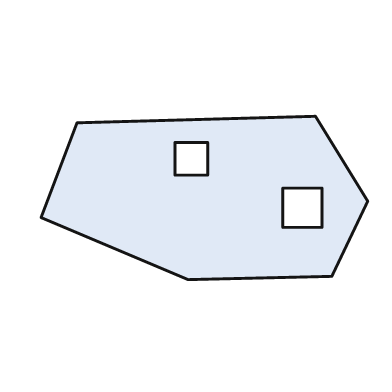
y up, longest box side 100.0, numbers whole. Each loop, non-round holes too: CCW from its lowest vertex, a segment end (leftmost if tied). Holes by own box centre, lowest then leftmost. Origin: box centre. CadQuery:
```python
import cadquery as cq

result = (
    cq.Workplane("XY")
    .moveTo(-5.0, -25.0)
    .lineTo(39.0, -24.0)
    .lineTo(50.0, -1.0)
    .lineTo(34.0, 25.0)
    .lineTo(-39.0, 23.0)
    .lineTo(-50.0, -6.0)
    .close()
    .moveTo(24.0, -9.0)
    .lineTo(36.0, -9.0)
    .lineTo(36.0, 3.0)
    .lineTo(24.0, 3.0)
    .close()
    .moveTo(-9.0, 7.0)
    .lineTo(1.0, 7.0)
    .lineTo(1.0, 17.0)
    .lineTo(-9.0, 17.0)
    .close()
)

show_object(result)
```